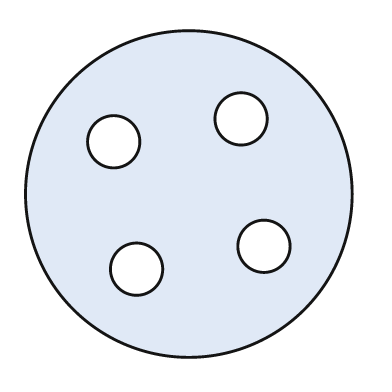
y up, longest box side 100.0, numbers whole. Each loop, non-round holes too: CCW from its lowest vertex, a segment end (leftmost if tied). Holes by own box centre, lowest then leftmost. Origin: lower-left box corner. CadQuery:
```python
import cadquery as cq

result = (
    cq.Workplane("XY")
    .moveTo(50.0, 50.0)
    .circle(50.0)
    .moveTo(34.0, 27.0)
    .circle(8.0)
    .moveTo(73.0, 34.0)
    .circle(8.0)
    .moveTo(27.0, 66.0)
    .circle(8.0)
    .moveTo(66.0, 73.0)
    .circle(8.0)
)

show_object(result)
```